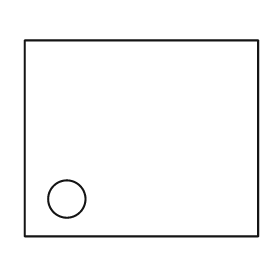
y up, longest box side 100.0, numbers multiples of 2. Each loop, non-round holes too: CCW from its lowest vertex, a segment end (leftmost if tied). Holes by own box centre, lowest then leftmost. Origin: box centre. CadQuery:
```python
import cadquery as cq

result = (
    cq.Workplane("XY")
    .moveTo(-50.0, -42.0)
    .lineTo(50.0, -42.0)
    .lineTo(50.0, 42.0)
    .lineTo(-50.0, 42.0)
    .close()
    .moveTo(-32.0, -26.0)
    .circle(8.0)
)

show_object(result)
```